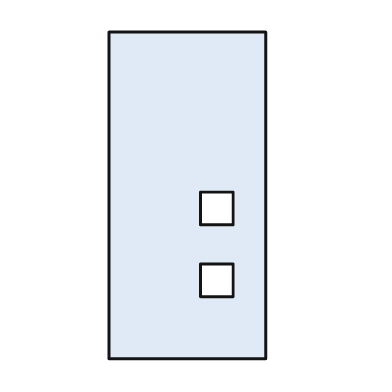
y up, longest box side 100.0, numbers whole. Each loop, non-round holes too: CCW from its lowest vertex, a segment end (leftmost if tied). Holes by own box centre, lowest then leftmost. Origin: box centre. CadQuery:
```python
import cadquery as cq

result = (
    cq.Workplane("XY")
    .moveTo(-24.0, -50.0)
    .lineTo(24.0, -50.0)
    .lineTo(24.0, 50.0)
    .lineTo(-24.0, 50.0)
    .close()
    .moveTo(4.0, -31.0)
    .lineTo(14.0, -31.0)
    .lineTo(14.0, -21.0)
    .lineTo(4.0, -21.0)
    .close()
    .moveTo(4.0, -9.0)
    .lineTo(14.0, -9.0)
    .lineTo(14.0, 1.0)
    .lineTo(4.0, 1.0)
    .close()
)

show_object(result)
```